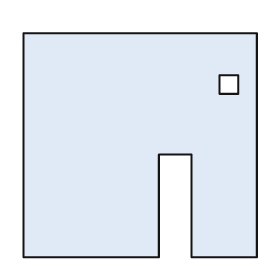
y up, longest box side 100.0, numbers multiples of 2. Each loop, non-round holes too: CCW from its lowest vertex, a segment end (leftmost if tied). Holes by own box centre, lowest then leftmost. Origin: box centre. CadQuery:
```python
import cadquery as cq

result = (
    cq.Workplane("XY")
    .moveTo(-50.0, -48.0)
    .lineTo(8.0, -48.0)
    .lineTo(8.0, -4.0)
    .lineTo(22.0, -4.0)
    .lineTo(22.0, -48.0)
    .lineTo(50.0, -48.0)
    .lineTo(50.0, 48.0)
    .lineTo(-50.0, 48.0)
    .close()
    .moveTo(34.0, 22.0)
    .lineTo(42.0, 22.0)
    .lineTo(42.0, 30.0)
    .lineTo(34.0, 30.0)
    .close()
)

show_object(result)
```